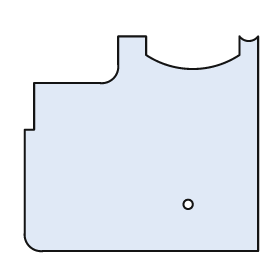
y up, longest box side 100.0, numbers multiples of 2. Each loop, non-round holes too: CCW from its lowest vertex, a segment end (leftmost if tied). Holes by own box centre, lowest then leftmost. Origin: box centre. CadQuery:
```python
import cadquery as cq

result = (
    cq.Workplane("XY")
    .moveTo(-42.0, -46.0)
    .lineTo(50.0, -46.0)
    .lineTo(50.0, 46.0)
    .threePointArc((46.0, 44.0), (42.0, 46.0))
    .lineTo(42.0, 38.0)
    .threePointArc((22.0, 32.0), (2.0, 38.0))
    .lineTo(2.0, 46.0)
    .lineTo(-10.0, 46.0)
    .lineTo(-10.0, 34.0)
    .threePointArc((-12.0, 28.0), (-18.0, 26.0))
    .lineTo(-46.0, 26.0)
    .lineTo(-46.0, 6.0)
    .lineTo(-50.0, 6.0)
    .lineTo(-50.0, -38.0)
    .threePointArc((-48.0, -44.0), (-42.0, -46.0))
    .close()
    .moveTo(20.0, -26.0)
    .circle(2.0)
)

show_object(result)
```